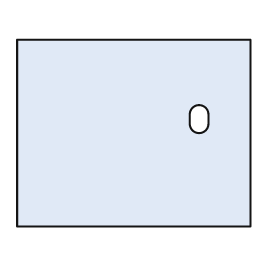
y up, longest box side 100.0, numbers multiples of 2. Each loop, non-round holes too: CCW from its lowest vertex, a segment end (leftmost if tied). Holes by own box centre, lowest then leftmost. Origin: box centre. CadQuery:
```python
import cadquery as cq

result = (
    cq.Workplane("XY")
    .moveTo(-50.0, -40.0)
    .lineTo(50.0, -40.0)
    .lineTo(50.0, 40.0)
    .lineTo(-50.0, 40.0)
    .close()
    .moveTo(24.0, 4.0)
    .threePointArc((28.0, 0.0), (32.0, 4.0))
    .lineTo(32.0, 8.0)
    .threePointArc((28.0, 12.0), (24.0, 8.0))
    .close()
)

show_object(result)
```